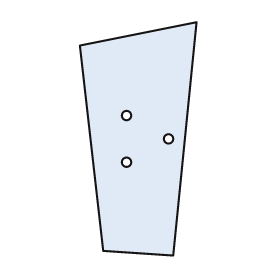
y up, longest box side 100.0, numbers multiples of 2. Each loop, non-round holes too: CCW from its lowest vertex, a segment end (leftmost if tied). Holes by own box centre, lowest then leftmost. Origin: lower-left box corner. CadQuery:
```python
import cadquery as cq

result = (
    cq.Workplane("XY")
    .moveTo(40.0, 0.0)
    .lineTo(50.0, 100.0)
    .lineTo(0.0, 90.0)
    .lineTo(10.0, 2.0)
    .close()
    .moveTo(20.0, 40.0)
    .circle(2.0)
    .moveTo(38.0, 50.0)
    .circle(2.0)
    .moveTo(20.0, 60.0)
    .circle(2.0)
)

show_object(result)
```